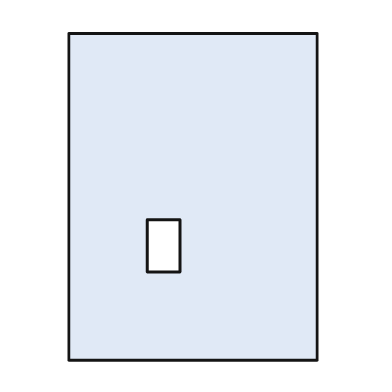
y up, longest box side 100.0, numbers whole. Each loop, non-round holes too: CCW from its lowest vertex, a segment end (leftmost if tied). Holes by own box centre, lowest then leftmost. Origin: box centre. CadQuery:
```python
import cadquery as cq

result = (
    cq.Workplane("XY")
    .moveTo(-38.0, -50.0)
    .lineTo(38.0, -50.0)
    .lineTo(38.0, 50.0)
    .lineTo(-38.0, 50.0)
    .close()
    .moveTo(-14.0, -23.0)
    .lineTo(-4.0, -23.0)
    .lineTo(-4.0, -7.0)
    .lineTo(-14.0, -7.0)
    .close()
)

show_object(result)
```